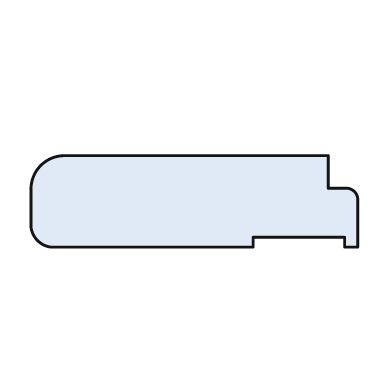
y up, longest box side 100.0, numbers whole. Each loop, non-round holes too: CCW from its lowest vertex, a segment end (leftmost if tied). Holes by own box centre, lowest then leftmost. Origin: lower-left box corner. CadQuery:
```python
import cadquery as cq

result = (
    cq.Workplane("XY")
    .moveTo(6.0, 0.0)
    .lineTo(68.0, 0.0)
    .lineTo(68.0, 3.0)
    .lineTo(96.0, 3.0)
    .lineTo(96.0, 0.0)
    .lineTo(100.0, 0.0)
    .lineTo(100.0, 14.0)
    .threePointArc((99.0, 17.0), (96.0, 18.0))
    .lineTo(91.0, 18.0)
    .lineTo(91.0, 28.0)
    .lineTo(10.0, 28.0)
    .threePointArc((3.0, 25.0), (0.0, 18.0))
    .lineTo(0.0, 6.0)
    .threePointArc((2.0, 2.0), (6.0, 0.0))
    .close()
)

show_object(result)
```